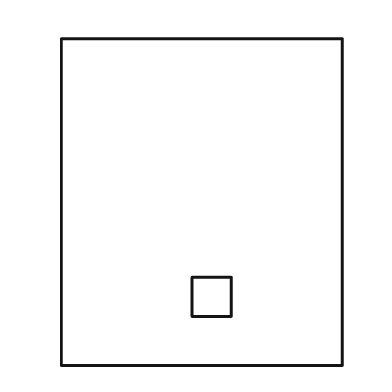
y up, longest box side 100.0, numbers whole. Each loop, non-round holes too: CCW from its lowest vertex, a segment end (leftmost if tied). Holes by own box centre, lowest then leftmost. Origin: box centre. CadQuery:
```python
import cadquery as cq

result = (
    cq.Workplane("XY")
    .moveTo(-43.0, -50.0)
    .lineTo(43.0, -50.0)
    .lineTo(43.0, 50.0)
    .lineTo(-43.0, 50.0)
    .close()
    .moveTo(-3.0, -35.0)
    .lineTo(9.0, -35.0)
    .lineTo(9.0, -23.0)
    .lineTo(-3.0, -23.0)
    .close()
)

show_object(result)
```